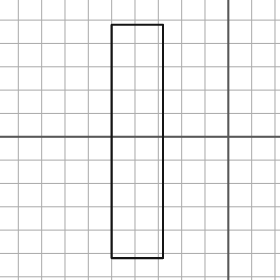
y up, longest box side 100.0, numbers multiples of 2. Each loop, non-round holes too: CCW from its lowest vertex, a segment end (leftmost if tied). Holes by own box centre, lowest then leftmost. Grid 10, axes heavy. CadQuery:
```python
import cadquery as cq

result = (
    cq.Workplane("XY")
    .moveTo(-50.0, -52.0)
    .lineTo(-28.0, -52.0)
    .lineTo(-28.0, 48.0)
    .lineTo(-50.0, 48.0)
    .close()
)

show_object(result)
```